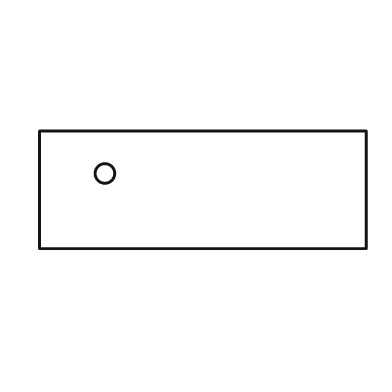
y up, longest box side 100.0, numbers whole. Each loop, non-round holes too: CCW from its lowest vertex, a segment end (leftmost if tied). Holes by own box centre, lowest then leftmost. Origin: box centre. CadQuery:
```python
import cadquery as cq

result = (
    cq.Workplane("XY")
    .moveTo(-50.0, -18.0)
    .lineTo(50.0, -18.0)
    .lineTo(50.0, 18.0)
    .lineTo(-50.0, 18.0)
    .close()
    .moveTo(-30.0, 5.0)
    .circle(3.0)
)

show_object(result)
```